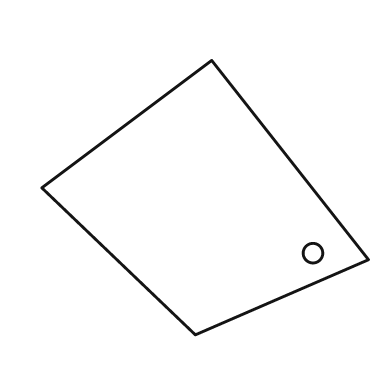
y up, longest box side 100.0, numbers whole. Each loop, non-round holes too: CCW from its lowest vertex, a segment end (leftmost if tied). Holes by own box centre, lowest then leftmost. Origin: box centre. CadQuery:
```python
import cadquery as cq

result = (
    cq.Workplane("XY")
    .moveTo(-3.0, -42.0)
    .lineTo(50.0, -19.0)
    .lineTo(2.0, 42.0)
    .lineTo(-50.0, 3.0)
    .close()
    .moveTo(33.0, -17.0)
    .circle(3.0)
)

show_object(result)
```